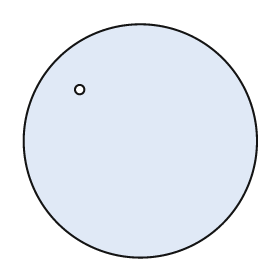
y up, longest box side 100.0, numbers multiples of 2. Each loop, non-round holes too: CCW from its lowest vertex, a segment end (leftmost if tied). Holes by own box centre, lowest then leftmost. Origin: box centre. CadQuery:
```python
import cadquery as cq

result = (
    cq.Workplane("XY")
    .moveTo(0.0, 0.0)
    .circle(50.0)
    .moveTo(-26.0, 22.0)
    .circle(2.0)
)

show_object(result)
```